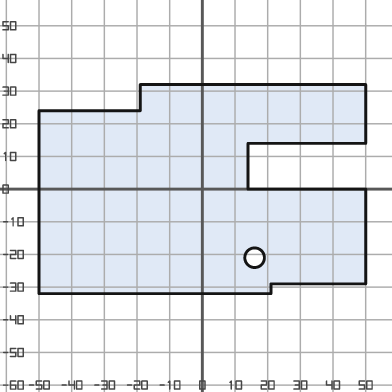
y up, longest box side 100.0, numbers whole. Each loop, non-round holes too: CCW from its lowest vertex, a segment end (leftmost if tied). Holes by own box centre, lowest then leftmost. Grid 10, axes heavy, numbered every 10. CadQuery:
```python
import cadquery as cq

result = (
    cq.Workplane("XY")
    .moveTo(-50.0, -32.0)
    .lineTo(21.0, -32.0)
    .lineTo(21.0, -29.0)
    .lineTo(50.0, -29.0)
    .lineTo(50.0, 0.0)
    .lineTo(14.0, 0.0)
    .lineTo(14.0, 14.0)
    .lineTo(50.0, 14.0)
    .lineTo(50.0, 32.0)
    .lineTo(-19.0, 32.0)
    .lineTo(-19.0, 24.0)
    .lineTo(-50.0, 24.0)
    .close()
    .moveTo(16.0, -21.0)
    .circle(3.0)
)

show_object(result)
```